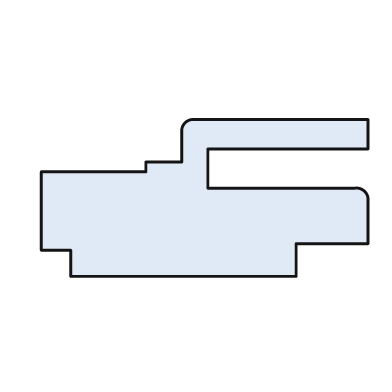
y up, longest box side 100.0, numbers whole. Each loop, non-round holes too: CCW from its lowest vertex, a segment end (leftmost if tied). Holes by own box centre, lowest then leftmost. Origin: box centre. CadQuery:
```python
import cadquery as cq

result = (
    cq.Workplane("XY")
    .moveTo(-41.0, -24.0)
    .lineTo(28.0, -24.0)
    .lineTo(28.0, -14.0)
    .lineTo(50.0, -14.0)
    .lineTo(50.0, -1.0)
    .threePointArc((49.0, 2.0), (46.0, 3.0))
    .lineTo(1.0, 3.0)
    .lineTo(1.0, 15.0)
    .lineTo(50.0, 15.0)
    .lineTo(50.0, 24.0)
    .lineTo(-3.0, 24.0)
    .threePointArc((-6.0, 23.0), (-7.0, 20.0))
    .lineTo(-7.0, 11.0)
    .lineTo(-18.0, 11.0)
    .lineTo(-18.0, 8.0)
    .lineTo(-50.0, 8.0)
    .lineTo(-50.0, -16.0)
    .lineTo(-41.0, -16.0)
    .close()
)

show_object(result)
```